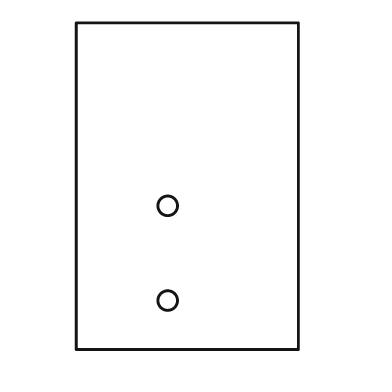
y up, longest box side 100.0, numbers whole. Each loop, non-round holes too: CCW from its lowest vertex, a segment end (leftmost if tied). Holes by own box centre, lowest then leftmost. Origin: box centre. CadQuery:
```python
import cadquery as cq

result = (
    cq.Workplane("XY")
    .moveTo(-34.0, -50.0)
    .lineTo(34.0, -50.0)
    .lineTo(34.0, 50.0)
    .lineTo(-34.0, 50.0)
    .close()
    .moveTo(-6.0, -35.0)
    .circle(3.0)
    .moveTo(-6.0, -6.0)
    .circle(3.0)
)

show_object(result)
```